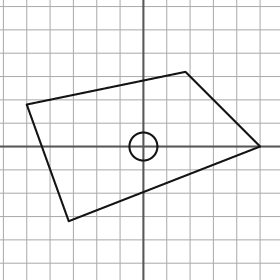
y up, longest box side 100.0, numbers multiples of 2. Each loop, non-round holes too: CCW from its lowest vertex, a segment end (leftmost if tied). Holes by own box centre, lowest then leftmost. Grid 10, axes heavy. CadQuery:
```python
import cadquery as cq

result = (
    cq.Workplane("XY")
    .moveTo(-32.0, -32.0)
    .lineTo(50.0, 0.0)
    .lineTo(18.0, 32.0)
    .lineTo(-50.0, 18.0)
    .close()
    .moveTo(0.0, 0.0)
    .circle(6.0)
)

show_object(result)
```